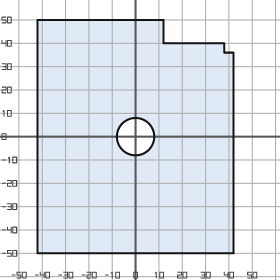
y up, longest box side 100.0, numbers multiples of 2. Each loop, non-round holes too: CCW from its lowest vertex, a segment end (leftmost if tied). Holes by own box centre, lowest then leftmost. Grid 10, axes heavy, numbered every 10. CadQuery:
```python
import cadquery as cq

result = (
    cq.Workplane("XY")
    .moveTo(-42.0, -50.0)
    .lineTo(42.0, -50.0)
    .lineTo(42.0, 36.0)
    .lineTo(38.0, 36.0)
    .lineTo(38.0, 40.0)
    .lineTo(12.0, 40.0)
    .lineTo(12.0, 50.0)
    .lineTo(-42.0, 50.0)
    .close()
    .moveTo(0.0, 0.0)
    .circle(8.0)
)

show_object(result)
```